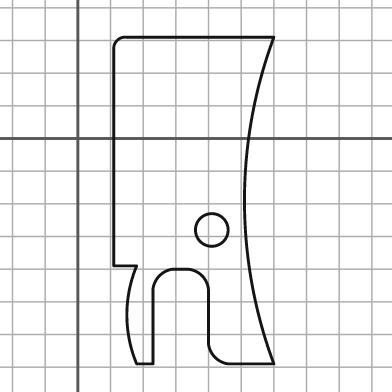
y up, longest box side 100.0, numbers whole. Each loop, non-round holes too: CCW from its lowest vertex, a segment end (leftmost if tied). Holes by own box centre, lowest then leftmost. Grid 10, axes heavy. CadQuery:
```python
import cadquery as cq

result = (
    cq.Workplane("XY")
    .moveTo(18.0, -69.0)
    .lineTo(23.0, -69.0)
    .lineTo(23.0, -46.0)
    .threePointArc((25.0, -42.0), (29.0, -40.0))
    .lineTo(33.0, -40.0)
    .threePointArc((38.0, -42.0), (40.0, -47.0))
    .lineTo(40.0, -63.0)
    .threePointArc((42.0, -67.0), (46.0, -69.0))
    .lineTo(60.0, -69.0)
    .threePointArc((51.0, -19.0), (60.0, 31.0))
    .lineTo(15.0, 31.0)
    .threePointArc((12.0, 30.0), (11.0, 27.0))
    .lineTo(11.0, -39.0)
    .lineTo(18.0, -39.0)
    .threePointArc((15.0, -54.0), (18.0, -69.0))
    .close()
    .moveTo(41.0, -28.0)
    .circle(5.0)
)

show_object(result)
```